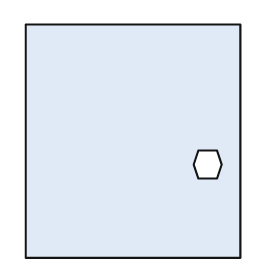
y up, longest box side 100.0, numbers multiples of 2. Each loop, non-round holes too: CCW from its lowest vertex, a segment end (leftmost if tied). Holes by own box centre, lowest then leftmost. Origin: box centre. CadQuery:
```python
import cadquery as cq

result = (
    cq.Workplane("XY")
    .moveTo(-46.0, -50.0)
    .lineTo(46.0, -50.0)
    .lineTo(46.0, 50.0)
    .lineTo(-46.0, 50.0)
    .close()
    .moveTo(28.0, -16.0)
    .lineTo(36.0, -16.0)
    .lineTo(38.0, -10.0)
    .lineTo(36.0, -4.0)
    .lineTo(28.0, -4.0)
    .lineTo(26.0, -10.0)
    .close()
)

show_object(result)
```